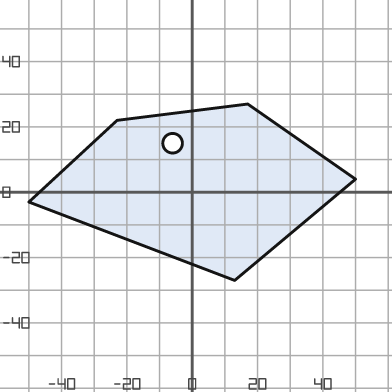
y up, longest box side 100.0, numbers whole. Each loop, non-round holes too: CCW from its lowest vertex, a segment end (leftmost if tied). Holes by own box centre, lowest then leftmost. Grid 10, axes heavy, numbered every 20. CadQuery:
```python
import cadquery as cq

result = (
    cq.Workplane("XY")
    .moveTo(13.0, -27.0)
    .lineTo(50.0, 4.0)
    .lineTo(17.0, 27.0)
    .lineTo(-23.0, 22.0)
    .lineTo(-50.0, -3.0)
    .close()
    .moveTo(-6.0, 15.0)
    .circle(3.0)
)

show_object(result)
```